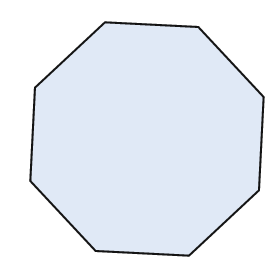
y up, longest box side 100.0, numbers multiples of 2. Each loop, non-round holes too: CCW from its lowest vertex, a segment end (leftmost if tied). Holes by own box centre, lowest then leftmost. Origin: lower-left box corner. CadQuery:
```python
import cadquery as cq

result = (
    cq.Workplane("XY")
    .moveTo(68.0, 0.0)
    .lineTo(98.0, 28.0)
    .lineTo(100.0, 68.0)
    .lineTo(72.0, 98.0)
    .lineTo(32.0, 100.0)
    .lineTo(2.0, 72.0)
    .lineTo(0.0, 32.0)
    .lineTo(28.0, 2.0)
    .close()
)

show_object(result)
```